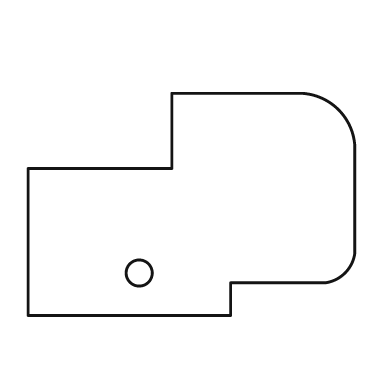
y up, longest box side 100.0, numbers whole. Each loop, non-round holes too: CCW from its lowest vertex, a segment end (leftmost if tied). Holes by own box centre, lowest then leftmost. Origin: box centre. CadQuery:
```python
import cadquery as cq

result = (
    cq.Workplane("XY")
    .moveTo(-50.0, -34.0)
    .lineTo(12.0, -34.0)
    .lineTo(12.0, -24.0)
    .lineTo(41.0, -24.0)
    .threePointArc((47.0, -21.0), (50.0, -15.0))
    .lineTo(50.0, 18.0)
    .threePointArc((45.0, 29.0), (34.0, 34.0))
    .lineTo(-6.0, 34.0)
    .lineTo(-6.0, 11.0)
    .lineTo(-50.0, 11.0)
    .close()
    .moveTo(-16.0, -21.0)
    .circle(4.0)
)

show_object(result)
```